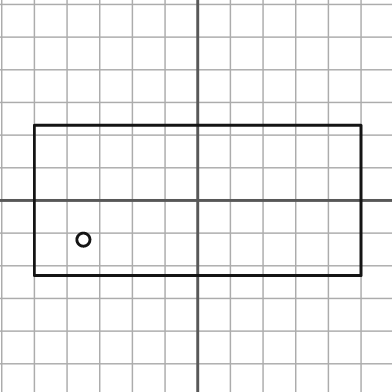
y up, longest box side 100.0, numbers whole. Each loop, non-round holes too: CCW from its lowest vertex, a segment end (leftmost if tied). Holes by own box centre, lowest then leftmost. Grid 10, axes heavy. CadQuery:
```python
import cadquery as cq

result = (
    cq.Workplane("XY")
    .moveTo(-50.0, -23.0)
    .lineTo(50.0, -23.0)
    .lineTo(50.0, 23.0)
    .lineTo(-50.0, 23.0)
    .close()
    .moveTo(-35.0, -12.0)
    .circle(2.0)
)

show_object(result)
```